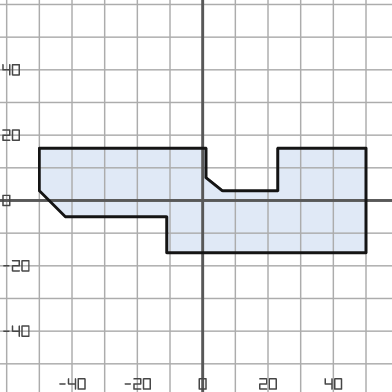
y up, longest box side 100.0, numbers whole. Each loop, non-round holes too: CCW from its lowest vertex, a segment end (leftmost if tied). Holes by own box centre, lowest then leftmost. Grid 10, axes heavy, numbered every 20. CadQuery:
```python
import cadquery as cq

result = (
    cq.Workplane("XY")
    .moveTo(-11.0, -16.0)
    .lineTo(50.0, -16.0)
    .lineTo(50.0, 16.0)
    .lineTo(23.0, 16.0)
    .lineTo(23.0, 3.0)
    .lineTo(6.0, 3.0)
    .lineTo(1.0, 7.0)
    .lineTo(1.0, 16.0)
    .lineTo(-50.0, 16.0)
    .lineTo(-50.0, 3.0)
    .lineTo(-42.0, -5.0)
    .lineTo(-11.0, -5.0)
    .close()
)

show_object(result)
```